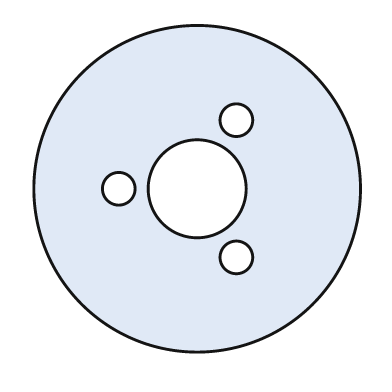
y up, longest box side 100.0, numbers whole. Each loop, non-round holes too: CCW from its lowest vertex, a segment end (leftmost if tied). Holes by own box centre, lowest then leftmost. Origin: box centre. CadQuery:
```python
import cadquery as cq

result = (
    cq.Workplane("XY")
    .moveTo(0.0, 0.0)
    .circle(50.0)
    .moveTo(12.0, -21.0)
    .circle(5.0)
    .moveTo(-24.0, 0.0)
    .circle(5.0)
    .moveTo(0.0, 0.0)
    .circle(15.0)
    .moveTo(12.0, 21.0)
    .circle(5.0)
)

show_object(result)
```